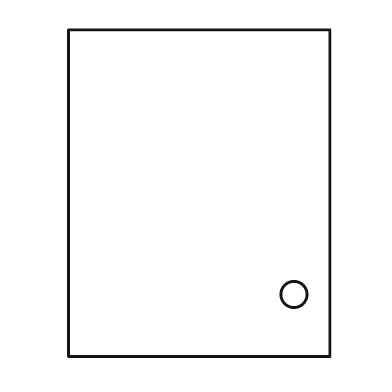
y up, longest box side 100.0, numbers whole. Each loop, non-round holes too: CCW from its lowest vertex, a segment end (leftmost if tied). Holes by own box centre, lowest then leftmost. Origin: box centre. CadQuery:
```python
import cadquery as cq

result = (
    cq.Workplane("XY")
    .moveTo(-40.0, -50.0)
    .lineTo(40.0, -50.0)
    .lineTo(40.0, 50.0)
    .lineTo(-40.0, 50.0)
    .close()
    .moveTo(29.0, -31.0)
    .circle(4.0)
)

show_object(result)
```